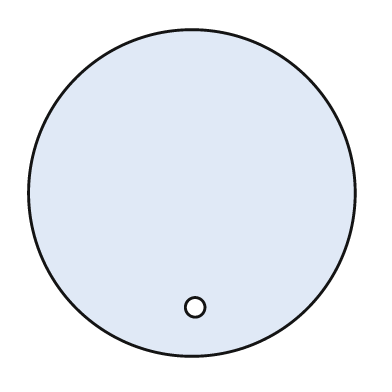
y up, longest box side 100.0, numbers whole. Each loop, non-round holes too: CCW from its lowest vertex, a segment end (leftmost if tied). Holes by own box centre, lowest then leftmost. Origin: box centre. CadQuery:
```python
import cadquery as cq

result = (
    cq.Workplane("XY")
    .moveTo(0.0, 0.0)
    .circle(50.0)
    .moveTo(1.0, -35.0)
    .circle(3.0)
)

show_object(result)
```